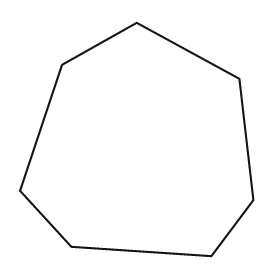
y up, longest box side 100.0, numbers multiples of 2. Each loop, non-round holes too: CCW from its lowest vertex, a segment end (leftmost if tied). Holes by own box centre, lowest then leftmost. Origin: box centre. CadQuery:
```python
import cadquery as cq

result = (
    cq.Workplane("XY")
    .moveTo(32.0, -50.0)
    .lineTo(50.0, -26.0)
    .lineTo(44.0, 26.0)
    .lineTo(0.0, 50.0)
    .lineTo(-32.0, 32.0)
    .lineTo(-50.0, -22.0)
    .lineTo(-28.0, -46.0)
    .close()
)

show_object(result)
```